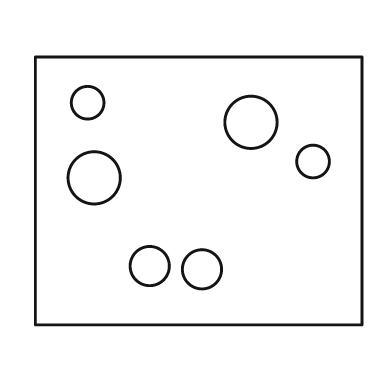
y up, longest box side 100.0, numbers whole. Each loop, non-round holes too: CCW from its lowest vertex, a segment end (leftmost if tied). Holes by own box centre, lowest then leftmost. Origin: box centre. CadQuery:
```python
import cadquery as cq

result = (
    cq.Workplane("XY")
    .moveTo(-50.0, -41.0)
    .lineTo(50.0, -41.0)
    .lineTo(50.0, 41.0)
    .lineTo(-50.0, 41.0)
    .close()
    .moveTo(1.0, -24.0)
    .circle(6.0)
    .moveTo(-15.0, -23.0)
    .circle(6.0)
    .moveTo(-32.0, 4.0)
    .circle(8.0)
    .moveTo(35.0, 9.0)
    .circle(5.0)
    .moveTo(16.0, 21.0)
    .circle(8.0)
    .moveTo(-34.0, 27.0)
    .circle(5.0)
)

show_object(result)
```